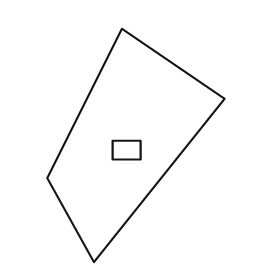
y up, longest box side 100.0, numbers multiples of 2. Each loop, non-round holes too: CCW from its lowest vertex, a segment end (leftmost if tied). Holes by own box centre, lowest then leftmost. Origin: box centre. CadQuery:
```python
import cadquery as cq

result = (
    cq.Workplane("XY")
    .moveTo(-18.0, -50.0)
    .lineTo(38.0, 20.0)
    .lineTo(-6.0, 50.0)
    .lineTo(-38.0, -14.0)
    .close()
    .moveTo(-10.0, -6.0)
    .lineTo(2.0, -6.0)
    .lineTo(2.0, 2.0)
    .lineTo(-10.0, 2.0)
    .close()
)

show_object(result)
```